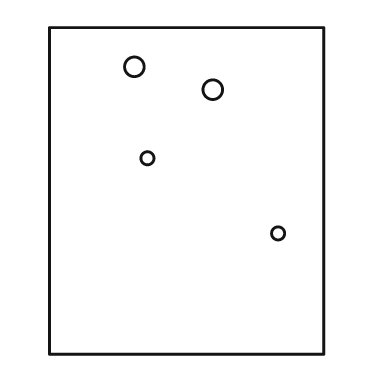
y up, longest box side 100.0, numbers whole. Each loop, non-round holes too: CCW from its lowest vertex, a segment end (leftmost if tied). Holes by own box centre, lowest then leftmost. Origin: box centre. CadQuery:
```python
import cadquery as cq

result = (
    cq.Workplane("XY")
    .moveTo(-42.0, -50.0)
    .lineTo(42.0, -50.0)
    .lineTo(42.0, 50.0)
    .lineTo(-42.0, 50.0)
    .close()
    .moveTo(28.0, -13.0)
    .circle(2.0)
    .moveTo(-12.0, 10.0)
    .circle(2.0)
    .moveTo(8.0, 31.0)
    .circle(3.0)
    .moveTo(-16.0, 38.0)
    .circle(3.0)
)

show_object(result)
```